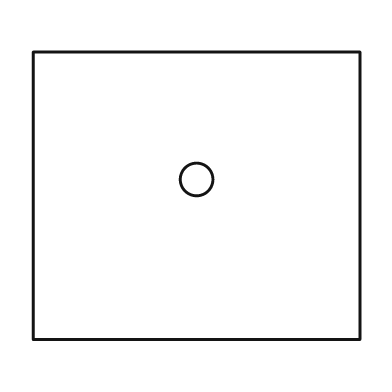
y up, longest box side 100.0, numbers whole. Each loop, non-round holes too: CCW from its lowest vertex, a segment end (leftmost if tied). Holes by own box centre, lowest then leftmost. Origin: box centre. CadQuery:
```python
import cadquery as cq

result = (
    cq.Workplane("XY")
    .moveTo(-50.0, -44.0)
    .lineTo(50.0, -44.0)
    .lineTo(50.0, 44.0)
    .lineTo(-50.0, 44.0)
    .close()
    .moveTo(0.0, 5.0)
    .circle(5.0)
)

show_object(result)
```